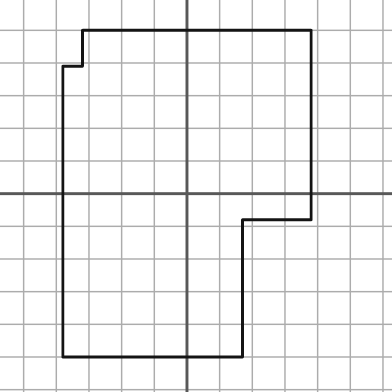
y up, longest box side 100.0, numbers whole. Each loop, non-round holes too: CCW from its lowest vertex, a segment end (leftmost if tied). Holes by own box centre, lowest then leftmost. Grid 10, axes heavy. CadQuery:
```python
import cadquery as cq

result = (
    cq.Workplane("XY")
    .moveTo(-38.0, -50.0)
    .lineTo(17.0, -50.0)
    .lineTo(17.0, -8.0)
    .lineTo(38.0, -8.0)
    .lineTo(38.0, 50.0)
    .lineTo(-32.0, 50.0)
    .lineTo(-32.0, 39.0)
    .lineTo(-38.0, 39.0)
    .close()
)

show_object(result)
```